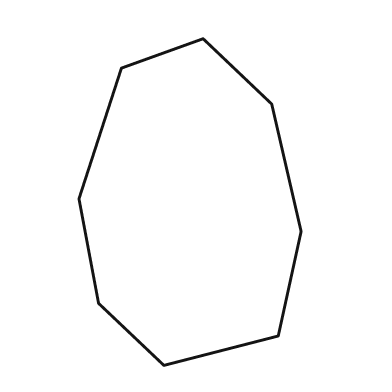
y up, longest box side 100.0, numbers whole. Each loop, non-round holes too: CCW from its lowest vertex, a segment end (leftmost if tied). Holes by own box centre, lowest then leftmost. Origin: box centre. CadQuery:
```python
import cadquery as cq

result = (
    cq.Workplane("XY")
    .moveTo(-8.0, -50.0)
    .lineTo(27.0, -41.0)
    .lineTo(34.0, -9.0)
    .lineTo(25.0, 30.0)
    .lineTo(4.0, 50.0)
    .lineTo(-21.0, 41.0)
    .lineTo(-34.0, 1.0)
    .lineTo(-28.0, -31.0)
    .close()
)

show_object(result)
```